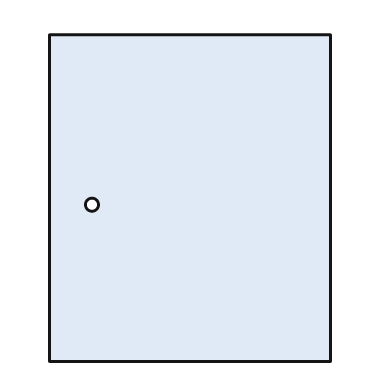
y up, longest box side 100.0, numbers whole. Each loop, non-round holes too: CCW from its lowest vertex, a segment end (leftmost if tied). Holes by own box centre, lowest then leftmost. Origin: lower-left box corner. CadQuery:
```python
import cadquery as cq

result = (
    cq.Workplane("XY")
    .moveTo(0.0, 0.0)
    .lineTo(86.0, 0.0)
    .lineTo(86.0, 100.0)
    .lineTo(0.0, 100.0)
    .close()
    .moveTo(13.0, 48.0)
    .circle(2.0)
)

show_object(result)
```